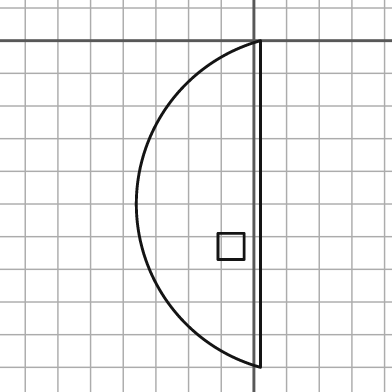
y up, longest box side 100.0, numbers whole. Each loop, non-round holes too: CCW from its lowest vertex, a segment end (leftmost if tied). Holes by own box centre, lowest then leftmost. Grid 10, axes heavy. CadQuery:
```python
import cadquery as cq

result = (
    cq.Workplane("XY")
    .moveTo(2.0, -100.0)
    .lineTo(2.0, 0.0)
    .threePointArc((-36.0, -50.0), (2.0, -100.0))
    .close()
    .moveTo(-11.0, -67.0)
    .lineTo(-3.0, -67.0)
    .lineTo(-3.0, -59.0)
    .lineTo(-11.0, -59.0)
    .close()
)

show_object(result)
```